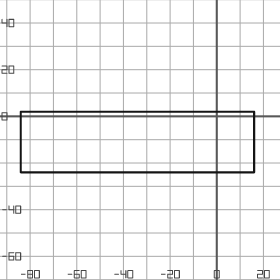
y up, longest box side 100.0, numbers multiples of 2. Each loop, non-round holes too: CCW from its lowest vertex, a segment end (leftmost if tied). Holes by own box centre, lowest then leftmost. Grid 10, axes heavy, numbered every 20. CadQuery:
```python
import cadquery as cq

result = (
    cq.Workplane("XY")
    .moveTo(-84.0, -24.0)
    .lineTo(16.0, -24.0)
    .lineTo(16.0, 2.0)
    .lineTo(-84.0, 2.0)
    .close()
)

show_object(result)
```